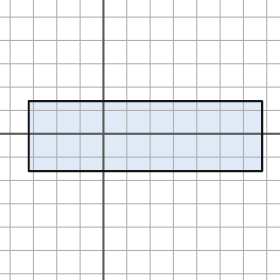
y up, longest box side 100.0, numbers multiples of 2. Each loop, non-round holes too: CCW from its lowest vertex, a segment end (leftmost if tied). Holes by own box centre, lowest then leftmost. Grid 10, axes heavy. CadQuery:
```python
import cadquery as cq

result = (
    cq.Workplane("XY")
    .moveTo(-32.0, -16.0)
    .lineTo(68.0, -16.0)
    .lineTo(68.0, 14.0)
    .lineTo(-32.0, 14.0)
    .close()
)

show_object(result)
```